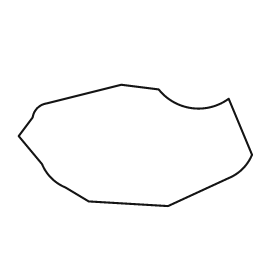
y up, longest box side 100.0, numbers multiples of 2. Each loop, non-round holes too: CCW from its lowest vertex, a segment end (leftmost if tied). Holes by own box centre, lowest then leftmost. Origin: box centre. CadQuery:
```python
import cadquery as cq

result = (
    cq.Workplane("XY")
    .moveTo(14.0, -26.0)
    .lineTo(40.0, -14.0)
    .threePointArc((46.0, -10.0), (50.0, -4.0))
    .lineTo(40.0, 20.0)
    .threePointArc((24.0, 16.0), (10.0, 24.0))
    .lineTo(-6.0, 26.0)
    .lineTo(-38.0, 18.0)
    .threePointArc((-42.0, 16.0), (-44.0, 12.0))
    .lineTo(-50.0, 4.0)
    .lineTo(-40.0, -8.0)
    .threePointArc((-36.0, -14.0), (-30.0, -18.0))
    .lineTo(-20.0, -24.0)
    .close()
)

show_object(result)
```